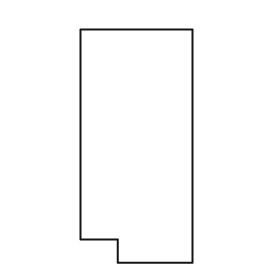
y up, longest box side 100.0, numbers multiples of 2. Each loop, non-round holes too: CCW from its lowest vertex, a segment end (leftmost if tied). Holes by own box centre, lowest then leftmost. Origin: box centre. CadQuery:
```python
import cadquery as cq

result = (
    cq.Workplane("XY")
    .moveTo(-8.0, -50.0)
    .lineTo(24.0, -50.0)
    .lineTo(24.0, 50.0)
    .lineTo(-24.0, 50.0)
    .lineTo(-24.0, -40.0)
    .lineTo(-8.0, -40.0)
    .close()
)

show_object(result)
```